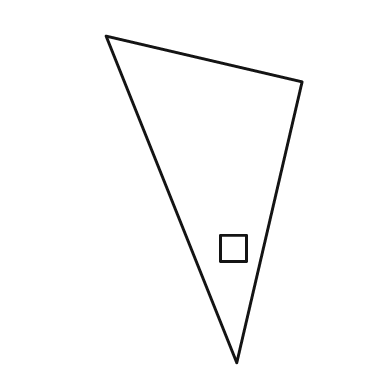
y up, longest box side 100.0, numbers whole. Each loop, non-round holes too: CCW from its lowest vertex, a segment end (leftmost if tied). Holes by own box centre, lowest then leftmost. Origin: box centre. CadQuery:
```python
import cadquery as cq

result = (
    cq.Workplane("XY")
    .moveTo(10.0, -50.0)
    .lineTo(30.0, 36.0)
    .lineTo(-30.0, 50.0)
    .close()
    .moveTo(5.0, -19.0)
    .lineTo(13.0, -19.0)
    .lineTo(13.0, -11.0)
    .lineTo(5.0, -11.0)
    .close()
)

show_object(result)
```